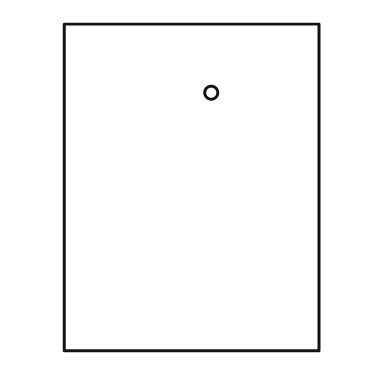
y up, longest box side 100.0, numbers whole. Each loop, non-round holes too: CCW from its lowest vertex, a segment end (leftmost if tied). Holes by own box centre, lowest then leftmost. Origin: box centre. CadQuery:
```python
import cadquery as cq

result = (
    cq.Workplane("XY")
    .moveTo(-39.0, -50.0)
    .lineTo(39.0, -50.0)
    .lineTo(39.0, 50.0)
    .lineTo(-39.0, 50.0)
    .close()
    .moveTo(6.0, 29.0)
    .circle(2.0)
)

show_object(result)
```